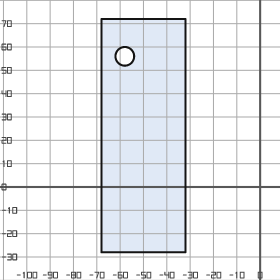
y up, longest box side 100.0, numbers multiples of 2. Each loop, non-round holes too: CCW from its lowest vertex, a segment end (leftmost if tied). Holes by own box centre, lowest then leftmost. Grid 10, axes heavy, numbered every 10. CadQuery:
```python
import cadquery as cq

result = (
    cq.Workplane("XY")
    .moveTo(-68.0, -28.0)
    .lineTo(-32.0, -28.0)
    .lineTo(-32.0, 72.0)
    .lineTo(-68.0, 72.0)
    .close()
    .moveTo(-58.0, 56.0)
    .circle(4.0)
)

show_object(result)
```